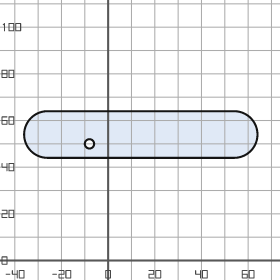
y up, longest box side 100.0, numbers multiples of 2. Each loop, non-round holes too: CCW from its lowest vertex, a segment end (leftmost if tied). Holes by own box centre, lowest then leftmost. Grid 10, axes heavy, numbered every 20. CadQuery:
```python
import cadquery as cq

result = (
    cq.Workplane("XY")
    .moveTo(-26.0, 44.0)
    .lineTo(54.0, 44.0)
    .threePointArc((64.0, 54.0), (54.0, 64.0))
    .lineTo(-26.0, 64.0)
    .threePointArc((-36.0, 54.0), (-26.0, 44.0))
    .close()
    .moveTo(-8.0, 50.0)
    .circle(2.0)
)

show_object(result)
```